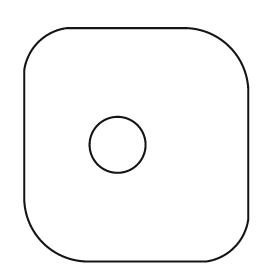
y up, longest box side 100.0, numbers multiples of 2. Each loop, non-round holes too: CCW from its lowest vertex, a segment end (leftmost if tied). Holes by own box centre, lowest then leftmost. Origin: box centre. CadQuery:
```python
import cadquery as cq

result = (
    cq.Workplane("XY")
    .moveTo(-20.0, -50.0)
    .lineTo(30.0, -50.0)
    .threePointArc((42.0, -44.0), (48.0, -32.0))
    .lineTo(48.0, 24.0)
    .threePointArc((40.0, 42.0), (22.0, 50.0))
    .lineTo(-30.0, 50.0)
    .threePointArc((-42.0, 44.0), (-48.0, 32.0))
    .lineTo(-48.0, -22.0)
    .threePointArc((-40.0, -42.0), (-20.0, -50.0))
    .close()
    .moveTo(-8.0, 0.0)
    .circle(12.0)
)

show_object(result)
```